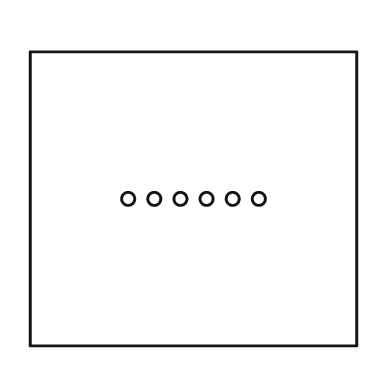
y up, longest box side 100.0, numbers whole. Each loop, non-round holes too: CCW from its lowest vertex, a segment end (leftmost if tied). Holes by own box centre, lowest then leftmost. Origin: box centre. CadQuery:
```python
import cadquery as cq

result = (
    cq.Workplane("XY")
    .moveTo(-50.0, -45.0)
    .lineTo(50.0, -45.0)
    .lineTo(50.0, 45.0)
    .lineTo(-50.0, 45.0)
    .close()
    .moveTo(-20.0, 0.0)
    .circle(2.0)
    .moveTo(-12.0, 0.0)
    .circle(2.0)
    .moveTo(-4.0, 0.0)
    .circle(2.0)
    .moveTo(4.0, 0.0)
    .circle(2.0)
    .moveTo(12.0, 0.0)
    .circle(2.0)
    .moveTo(20.0, 0.0)
    .circle(2.0)
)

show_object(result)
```